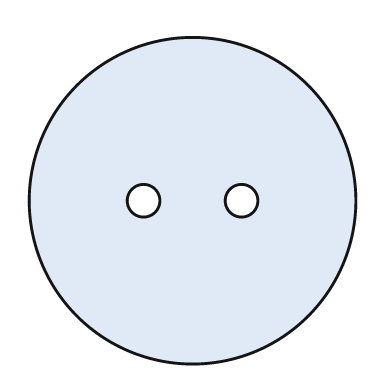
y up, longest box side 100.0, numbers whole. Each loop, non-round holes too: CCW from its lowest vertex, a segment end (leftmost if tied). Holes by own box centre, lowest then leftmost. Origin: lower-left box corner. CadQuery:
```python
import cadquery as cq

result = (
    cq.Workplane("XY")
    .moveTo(50.0, 50.0)
    .circle(50.0)
    .moveTo(35.0, 50.0)
    .circle(5.0)
    .moveTo(65.0, 50.0)
    .circle(5.0)
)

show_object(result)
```